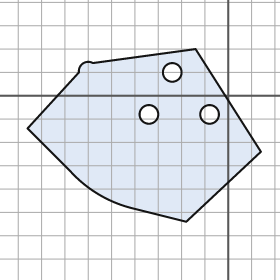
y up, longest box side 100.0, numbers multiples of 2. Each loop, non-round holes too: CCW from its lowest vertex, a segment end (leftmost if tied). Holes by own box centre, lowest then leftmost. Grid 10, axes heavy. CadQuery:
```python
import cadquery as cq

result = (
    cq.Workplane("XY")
    .moveTo(-18.0, -54.0)
    .lineTo(14.0, -24.0)
    .lineTo(-14.0, 20.0)
    .lineTo(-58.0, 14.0)
    .threePointArc((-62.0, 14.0), (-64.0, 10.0))
    .lineTo(-86.0, -14.0)
    .lineTo(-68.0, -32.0)
    .threePointArc((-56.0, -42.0), (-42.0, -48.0))
    .close()
    .moveTo(-34.0, -8.0)
    .circle(4.0)
    .moveTo(-8.0, -8.0)
    .circle(4.0)
    .moveTo(-24.0, 10.0)
    .circle(4.0)
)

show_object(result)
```